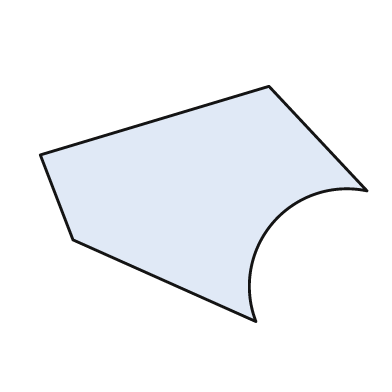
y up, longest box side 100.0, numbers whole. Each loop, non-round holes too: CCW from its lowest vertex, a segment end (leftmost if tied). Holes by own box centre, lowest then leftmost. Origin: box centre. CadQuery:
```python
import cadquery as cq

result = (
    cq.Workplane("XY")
    .moveTo(16.0, -36.0)
    .threePointArc((21.0, -6.0), (50.0, 4.0))
    .lineTo(20.0, 36.0)
    .lineTo(-50.0, 15.0)
    .lineTo(-40.0, -11.0)
    .close()
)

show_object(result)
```